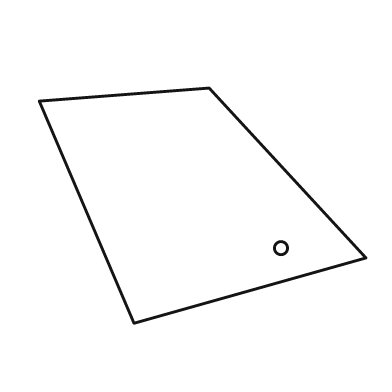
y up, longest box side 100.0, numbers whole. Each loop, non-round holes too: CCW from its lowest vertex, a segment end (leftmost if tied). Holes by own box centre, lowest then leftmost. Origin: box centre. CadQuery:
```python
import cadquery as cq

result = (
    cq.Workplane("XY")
    .moveTo(-21.0, -36.0)
    .lineTo(50.0, -16.0)
    .lineTo(2.0, 36.0)
    .lineTo(-50.0, 32.0)
    .close()
    .moveTo(24.0, -13.0)
    .circle(2.0)
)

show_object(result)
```